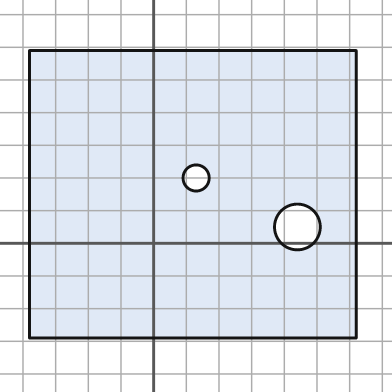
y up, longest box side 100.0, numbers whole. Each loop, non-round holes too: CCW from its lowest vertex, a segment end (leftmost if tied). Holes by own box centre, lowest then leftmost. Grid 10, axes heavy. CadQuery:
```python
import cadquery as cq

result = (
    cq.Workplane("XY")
    .moveTo(-38.0, -29.0)
    .lineTo(62.0, -29.0)
    .lineTo(62.0, 59.0)
    .lineTo(-38.0, 59.0)
    .close()
    .moveTo(44.0, 5.0)
    .circle(7.0)
    .moveTo(13.0, 20.0)
    .circle(4.0)
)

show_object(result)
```